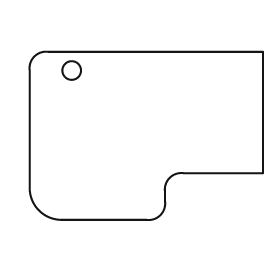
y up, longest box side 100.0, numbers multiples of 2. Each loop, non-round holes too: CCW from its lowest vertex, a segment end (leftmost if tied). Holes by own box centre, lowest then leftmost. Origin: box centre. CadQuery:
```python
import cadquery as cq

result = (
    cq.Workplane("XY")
    .moveTo(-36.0, -36.0)
    .lineTo(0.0, -36.0)
    .threePointArc((6.0, -34.0), (8.0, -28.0))
    .lineTo(8.0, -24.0)
    .threePointArc((10.0, -18.0), (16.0, -16.0))
    .lineTo(50.0, -16.0)
    .lineTo(50.0, 36.0)
    .lineTo(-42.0, 36.0)
    .threePointArc((-48.0, 34.0), (-50.0, 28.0))
    .lineTo(-50.0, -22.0)
    .threePointArc((-46.0, -32.0), (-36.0, -36.0))
    .close()
    .moveTo(-32.0, 28.0)
    .circle(4.0)
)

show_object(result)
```